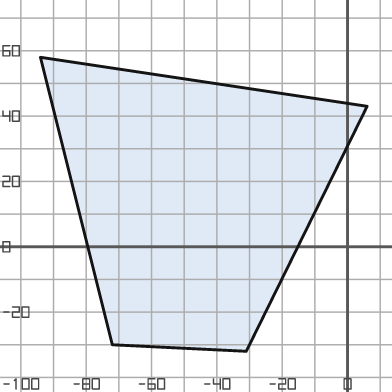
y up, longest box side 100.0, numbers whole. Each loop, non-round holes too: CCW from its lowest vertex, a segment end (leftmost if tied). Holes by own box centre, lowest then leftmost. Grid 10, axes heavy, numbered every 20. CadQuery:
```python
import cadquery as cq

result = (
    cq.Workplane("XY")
    .moveTo(-31.0, -32.0)
    .lineTo(6.0, 43.0)
    .lineTo(-94.0, 58.0)
    .lineTo(-72.0, -30.0)
    .close()
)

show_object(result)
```